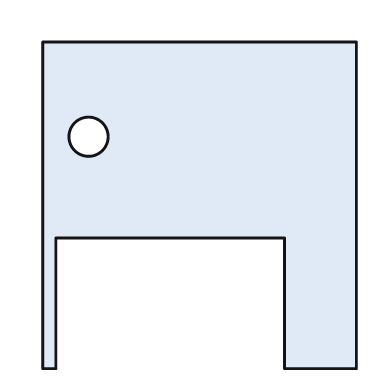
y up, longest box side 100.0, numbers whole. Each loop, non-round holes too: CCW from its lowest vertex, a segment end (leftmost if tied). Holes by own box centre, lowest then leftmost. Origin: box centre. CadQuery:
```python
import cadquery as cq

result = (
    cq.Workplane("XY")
    .moveTo(-48.0, -50.0)
    .lineTo(-44.0, -50.0)
    .lineTo(-44.0, -10.0)
    .lineTo(26.0, -10.0)
    .lineTo(26.0, -50.0)
    .lineTo(48.0, -50.0)
    .lineTo(48.0, 50.0)
    .lineTo(-48.0, 50.0)
    .close()
    .moveTo(-34.0, 21.0)
    .circle(6.0)
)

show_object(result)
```